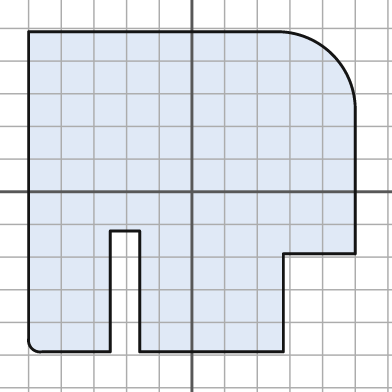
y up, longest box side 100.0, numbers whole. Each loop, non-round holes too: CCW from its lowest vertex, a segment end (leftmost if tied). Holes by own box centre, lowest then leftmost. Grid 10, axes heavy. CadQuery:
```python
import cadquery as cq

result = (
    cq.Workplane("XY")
    .moveTo(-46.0, -49.0)
    .lineTo(-25.0, -49.0)
    .lineTo(-25.0, -12.0)
    .lineTo(-16.0, -12.0)
    .lineTo(-16.0, -49.0)
    .lineTo(28.0, -49.0)
    .lineTo(28.0, -19.0)
    .lineTo(50.0, -19.0)
    .lineTo(50.0, 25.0)
    .threePointArc((43.0, 42.0), (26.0, 49.0))
    .lineTo(-50.0, 49.0)
    .lineTo(-50.0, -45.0)
    .threePointArc((-49.0, -48.0), (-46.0, -49.0))
    .close()
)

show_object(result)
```